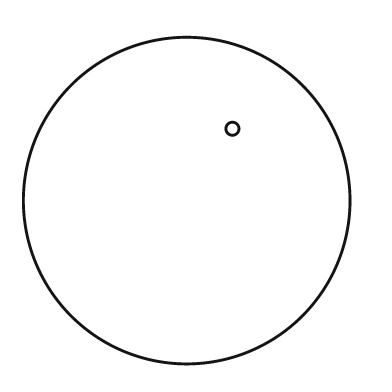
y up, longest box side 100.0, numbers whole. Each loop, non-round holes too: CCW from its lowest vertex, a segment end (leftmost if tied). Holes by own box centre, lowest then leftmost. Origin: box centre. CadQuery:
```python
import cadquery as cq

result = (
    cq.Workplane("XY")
    .moveTo(0.0, 0.0)
    .circle(50.0)
    .moveTo(14.0, 22.0)
    .circle(2.0)
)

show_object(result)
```